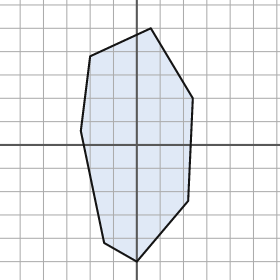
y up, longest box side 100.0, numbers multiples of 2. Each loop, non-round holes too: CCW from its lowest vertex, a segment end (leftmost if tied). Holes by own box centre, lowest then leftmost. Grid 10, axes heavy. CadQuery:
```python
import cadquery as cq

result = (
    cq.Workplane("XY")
    .moveTo(0.0, -50.0)
    .lineTo(22.0, -24.0)
    .lineTo(24.0, 20.0)
    .lineTo(6.0, 50.0)
    .lineTo(-20.0, 38.0)
    .lineTo(-24.0, 6.0)
    .lineTo(-14.0, -42.0)
    .close()
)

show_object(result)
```